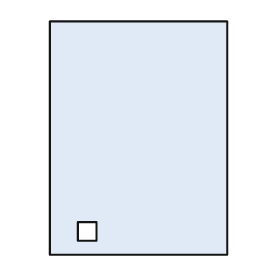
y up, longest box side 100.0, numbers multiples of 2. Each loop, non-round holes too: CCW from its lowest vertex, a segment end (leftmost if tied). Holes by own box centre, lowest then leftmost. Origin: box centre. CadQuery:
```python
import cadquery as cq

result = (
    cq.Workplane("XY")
    .moveTo(-38.0, -50.0)
    .lineTo(38.0, -50.0)
    .lineTo(38.0, 50.0)
    .lineTo(-38.0, 50.0)
    .close()
    .moveTo(-26.0, -44.0)
    .lineTo(-18.0, -44.0)
    .lineTo(-18.0, -36.0)
    .lineTo(-26.0, -36.0)
    .close()
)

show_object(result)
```